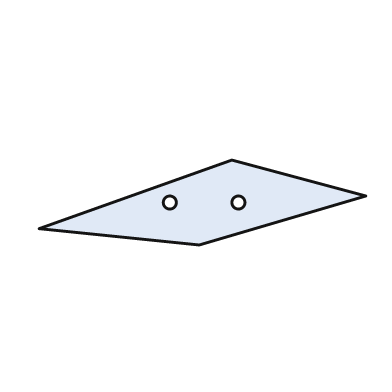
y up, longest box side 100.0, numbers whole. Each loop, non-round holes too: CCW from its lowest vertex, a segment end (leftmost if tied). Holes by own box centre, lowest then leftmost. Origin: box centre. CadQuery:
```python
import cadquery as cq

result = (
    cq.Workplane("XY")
    .moveTo(-1.0, -13.0)
    .lineTo(50.0, 2.0)
    .lineTo(9.0, 13.0)
    .lineTo(-50.0, -8.0)
    .close()
    .moveTo(-10.0, 0.0)
    .circle(2.0)
    .moveTo(11.0, 0.0)
    .circle(2.0)
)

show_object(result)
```